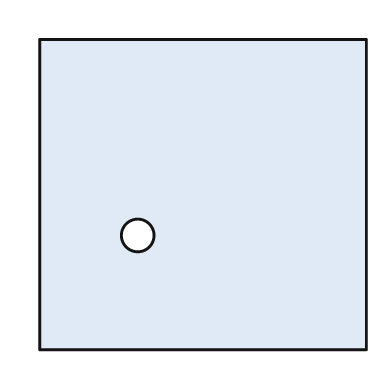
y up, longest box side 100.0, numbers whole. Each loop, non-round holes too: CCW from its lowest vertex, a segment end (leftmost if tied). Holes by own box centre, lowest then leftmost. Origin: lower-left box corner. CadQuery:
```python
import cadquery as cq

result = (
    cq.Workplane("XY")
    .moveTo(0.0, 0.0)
    .lineTo(100.0, 0.0)
    .lineTo(100.0, 95.0)
    .lineTo(0.0, 95.0)
    .close()
    .moveTo(30.0, 35.0)
    .circle(5.0)
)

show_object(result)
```